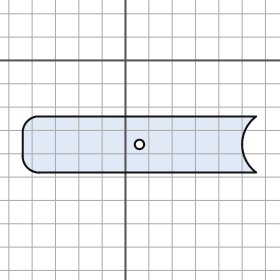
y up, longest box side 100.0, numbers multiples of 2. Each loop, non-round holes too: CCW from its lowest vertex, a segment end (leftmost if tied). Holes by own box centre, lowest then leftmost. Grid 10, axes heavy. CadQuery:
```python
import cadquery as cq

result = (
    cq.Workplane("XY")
    .moveTo(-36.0, -48.0)
    .lineTo(56.0, -48.0)
    .threePointArc((50.0, -36.0), (56.0, -24.0))
    .lineTo(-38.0, -24.0)
    .threePointArc((-42.0, -26.0), (-44.0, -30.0))
    .lineTo(-44.0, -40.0)
    .threePointArc((-42.0, -46.0), (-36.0, -48.0))
    .close()
    .moveTo(6.0, -36.0)
    .circle(2.0)
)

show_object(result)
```